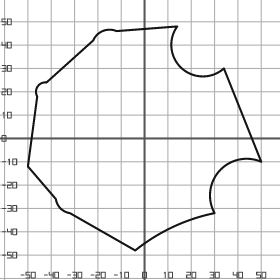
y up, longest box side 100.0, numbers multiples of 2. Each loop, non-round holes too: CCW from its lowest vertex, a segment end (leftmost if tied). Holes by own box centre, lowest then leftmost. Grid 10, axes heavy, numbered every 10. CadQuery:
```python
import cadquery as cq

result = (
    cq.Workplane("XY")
    .moveTo(-4.0, -48.0)
    .threePointArc((12.0, -38.0), (30.0, -32.0))
    .threePointArc((32.0, -14.0), (50.0, -10.0))
    .lineTo(34.0, 30.0)
    .threePointArc((16.0, 30.0), (14.0, 48.0))
    .lineTo(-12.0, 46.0)
    .threePointArc((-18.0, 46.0), (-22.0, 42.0))
    .lineTo(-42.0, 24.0)
    .threePointArc((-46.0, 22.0), (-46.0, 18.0))
    .lineTo(-50.0, -12.0)
    .lineTo(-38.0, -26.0)
    .threePointArc((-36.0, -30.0), (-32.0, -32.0))
    .close()
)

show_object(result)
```